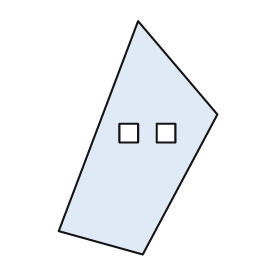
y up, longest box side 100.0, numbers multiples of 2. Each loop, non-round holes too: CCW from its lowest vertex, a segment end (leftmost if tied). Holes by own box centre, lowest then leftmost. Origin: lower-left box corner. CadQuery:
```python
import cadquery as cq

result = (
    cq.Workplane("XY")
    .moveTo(36.0, 0.0)
    .lineTo(68.0, 60.0)
    .lineTo(34.0, 100.0)
    .lineTo(0.0, 10.0)
    .close()
    .moveTo(26.0, 48.0)
    .lineTo(34.0, 48.0)
    .lineTo(34.0, 56.0)
    .lineTo(26.0, 56.0)
    .close()
    .moveTo(42.0, 48.0)
    .lineTo(50.0, 48.0)
    .lineTo(50.0, 56.0)
    .lineTo(42.0, 56.0)
    .close()
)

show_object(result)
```